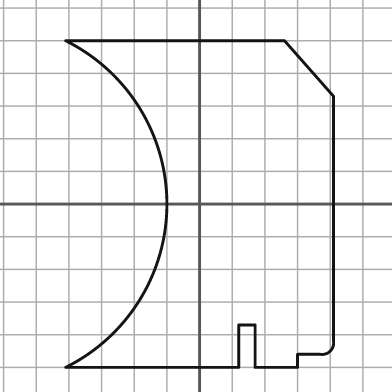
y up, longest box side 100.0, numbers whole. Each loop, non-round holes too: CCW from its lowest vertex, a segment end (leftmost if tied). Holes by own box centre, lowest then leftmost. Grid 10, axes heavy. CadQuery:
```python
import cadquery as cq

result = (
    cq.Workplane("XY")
    .moveTo(-41.0, -50.0)
    .lineTo(12.0, -50.0)
    .lineTo(12.0, -37.0)
    .lineTo(17.0, -37.0)
    .lineTo(17.0, -50.0)
    .lineTo(30.0, -50.0)
    .lineTo(30.0, -46.0)
    .lineTo(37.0, -46.0)
    .threePointArc((40.0, -45.0), (41.0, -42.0))
    .lineTo(41.0, 33.0)
    .lineTo(26.0, 50.0)
    .lineTo(-41.0, 50.0)
    .threePointArc((-10.0, 0.0), (-41.0, -50.0))
    .close()
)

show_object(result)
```